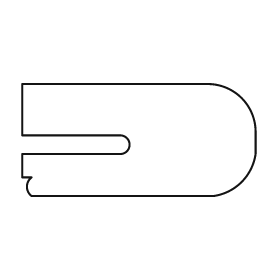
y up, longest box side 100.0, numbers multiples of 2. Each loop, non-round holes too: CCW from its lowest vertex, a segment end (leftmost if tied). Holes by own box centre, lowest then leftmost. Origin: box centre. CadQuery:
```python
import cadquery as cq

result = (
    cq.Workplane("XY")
    .moveTo(-46.0, -24.0)
    .lineTo(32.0, -24.0)
    .threePointArc((44.0, -18.0), (50.0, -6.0))
    .lineTo(50.0, 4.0)
    .threePointArc((44.0, 18.0), (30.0, 24.0))
    .lineTo(-50.0, 24.0)
    .lineTo(-50.0, 2.0)
    .lineTo(-8.0, 2.0)
    .threePointArc((-4.0, -2.0), (-8.0, -6.0))
    .lineTo(-50.0, -6.0)
    .lineTo(-50.0, -16.0)
    .lineTo(-46.0, -16.0)
    .threePointArc((-48.0, -20.0), (-46.0, -24.0))
    .close()
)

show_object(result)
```